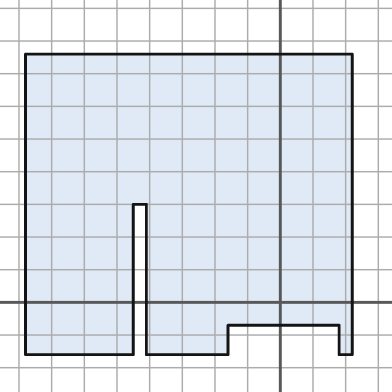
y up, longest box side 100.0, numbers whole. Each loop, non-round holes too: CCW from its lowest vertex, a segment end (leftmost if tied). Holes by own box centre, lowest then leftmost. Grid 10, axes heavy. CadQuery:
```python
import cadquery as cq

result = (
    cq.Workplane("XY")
    .moveTo(-78.0, -16.0)
    .lineTo(-45.0, -16.0)
    .lineTo(-45.0, 30.0)
    .lineTo(-41.0, 30.0)
    .lineTo(-41.0, -16.0)
    .lineTo(-16.0, -16.0)
    .lineTo(-16.0, -7.0)
    .lineTo(18.0, -7.0)
    .lineTo(18.0, -16.0)
    .lineTo(22.0, -16.0)
    .lineTo(22.0, 76.0)
    .lineTo(-78.0, 76.0)
    .close()
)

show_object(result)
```